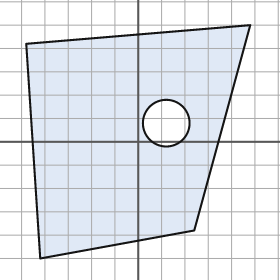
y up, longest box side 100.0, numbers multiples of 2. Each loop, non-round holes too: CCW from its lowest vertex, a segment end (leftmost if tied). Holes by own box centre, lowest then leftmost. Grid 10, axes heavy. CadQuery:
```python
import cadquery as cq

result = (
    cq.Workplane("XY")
    .moveTo(-42.0, -50.0)
    .lineTo(24.0, -38.0)
    .lineTo(48.0, 50.0)
    .lineTo(-48.0, 42.0)
    .close()
    .moveTo(12.0, 8.0)
    .circle(10.0)
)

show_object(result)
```